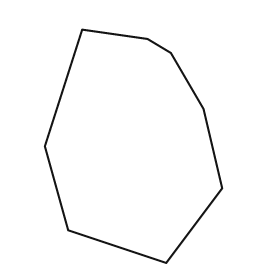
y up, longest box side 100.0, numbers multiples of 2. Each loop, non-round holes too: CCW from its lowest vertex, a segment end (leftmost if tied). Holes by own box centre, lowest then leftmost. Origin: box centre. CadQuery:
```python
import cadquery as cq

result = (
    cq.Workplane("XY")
    .moveTo(14.0, -50.0)
    .lineTo(38.0, -18.0)
    .lineTo(30.0, 16.0)
    .lineTo(16.0, 40.0)
    .lineTo(6.0, 46.0)
    .lineTo(-22.0, 50.0)
    .lineTo(-38.0, 0.0)
    .lineTo(-28.0, -36.0)
    .close()
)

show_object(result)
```